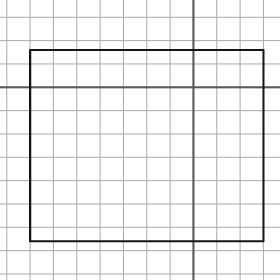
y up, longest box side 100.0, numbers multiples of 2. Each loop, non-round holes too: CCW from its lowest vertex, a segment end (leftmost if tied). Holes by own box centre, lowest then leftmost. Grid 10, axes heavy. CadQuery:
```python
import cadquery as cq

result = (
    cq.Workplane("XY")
    .moveTo(-70.0, -66.0)
    .lineTo(30.0, -66.0)
    .lineTo(30.0, 16.0)
    .lineTo(-70.0, 16.0)
    .close()
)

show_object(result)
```